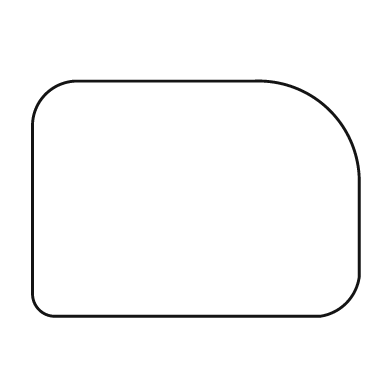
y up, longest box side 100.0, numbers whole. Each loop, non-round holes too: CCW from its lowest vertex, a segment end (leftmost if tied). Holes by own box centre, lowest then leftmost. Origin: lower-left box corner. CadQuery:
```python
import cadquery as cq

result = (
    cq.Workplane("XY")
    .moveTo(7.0, 0.0)
    .lineTo(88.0, 0.0)
    .threePointArc((96.0, 4.0), (100.0, 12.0))
    .lineTo(100.0, 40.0)
    .threePointArc((91.0, 63.0), (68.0, 72.0))
    .lineTo(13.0, 72.0)
    .threePointArc((4.0, 68.0), (0.0, 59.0))
    .lineTo(0.0, 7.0)
    .threePointArc((2.0, 2.0), (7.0, 0.0))
    .close()
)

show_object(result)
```